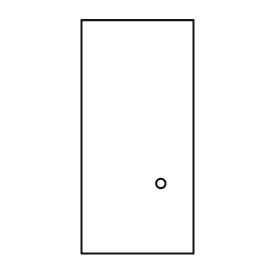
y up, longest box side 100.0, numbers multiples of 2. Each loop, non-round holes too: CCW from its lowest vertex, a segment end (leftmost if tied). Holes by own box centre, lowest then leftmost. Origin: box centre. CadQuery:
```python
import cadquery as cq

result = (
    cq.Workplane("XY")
    .moveTo(-24.0, -50.0)
    .lineTo(24.0, -50.0)
    .lineTo(24.0, 50.0)
    .lineTo(-24.0, 50.0)
    .close()
    .moveTo(10.0, -20.0)
    .circle(2.0)
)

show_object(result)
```